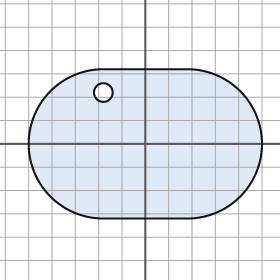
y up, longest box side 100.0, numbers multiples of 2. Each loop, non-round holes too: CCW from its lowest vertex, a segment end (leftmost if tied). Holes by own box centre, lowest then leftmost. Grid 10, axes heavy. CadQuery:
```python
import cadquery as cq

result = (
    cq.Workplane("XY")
    .moveTo(-18.0, -32.0)
    .lineTo(18.0, -32.0)
    .threePointArc((50.0, 0.0), (18.0, 32.0))
    .lineTo(-18.0, 32.0)
    .threePointArc((-50.0, 0.0), (-18.0, -32.0))
    .close()
    .moveTo(-18.0, 22.0)
    .circle(4.0)
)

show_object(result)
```